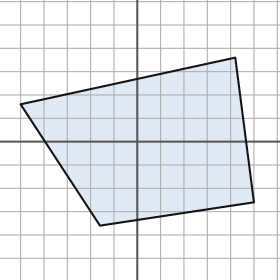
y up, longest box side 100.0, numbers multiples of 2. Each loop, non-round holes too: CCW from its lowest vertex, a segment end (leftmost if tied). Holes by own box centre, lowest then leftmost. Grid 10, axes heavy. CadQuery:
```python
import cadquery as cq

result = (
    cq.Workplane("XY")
    .moveTo(-16.0, -36.0)
    .lineTo(50.0, -26.0)
    .lineTo(42.0, 36.0)
    .lineTo(-50.0, 16.0)
    .close()
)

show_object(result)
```